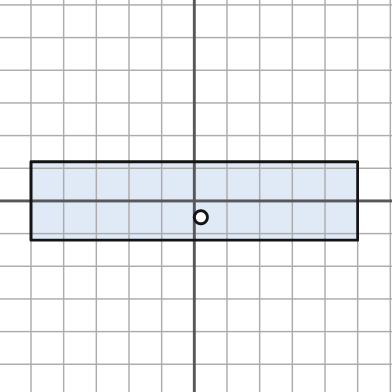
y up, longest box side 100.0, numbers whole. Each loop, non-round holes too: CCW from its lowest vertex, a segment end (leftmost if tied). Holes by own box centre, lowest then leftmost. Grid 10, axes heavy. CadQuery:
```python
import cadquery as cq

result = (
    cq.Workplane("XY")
    .moveTo(-50.0, -12.0)
    .lineTo(50.0, -12.0)
    .lineTo(50.0, 12.0)
    .lineTo(-50.0, 12.0)
    .close()
    .moveTo(2.0, -5.0)
    .circle(2.0)
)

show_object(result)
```